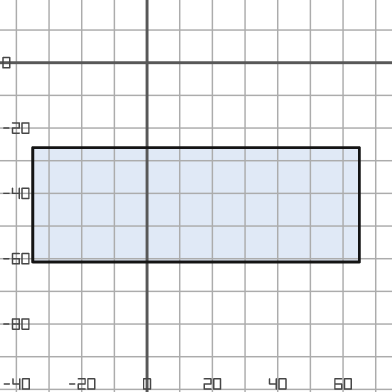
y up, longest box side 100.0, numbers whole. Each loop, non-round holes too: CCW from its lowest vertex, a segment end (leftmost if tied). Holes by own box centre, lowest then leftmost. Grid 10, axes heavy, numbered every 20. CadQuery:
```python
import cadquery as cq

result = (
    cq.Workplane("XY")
    .moveTo(-35.0, -61.0)
    .lineTo(65.0, -61.0)
    .lineTo(65.0, -26.0)
    .lineTo(-35.0, -26.0)
    .close()
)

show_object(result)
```